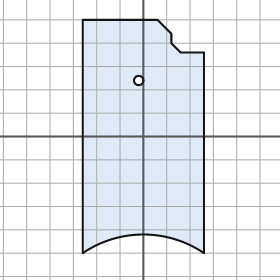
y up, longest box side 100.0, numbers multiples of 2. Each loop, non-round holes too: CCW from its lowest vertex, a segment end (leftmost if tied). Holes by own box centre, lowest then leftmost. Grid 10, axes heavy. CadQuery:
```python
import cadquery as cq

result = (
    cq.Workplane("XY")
    .moveTo(-26.0, -50.0)
    .threePointArc((0.0, -42.0), (26.0, -50.0))
    .lineTo(26.0, 36.0)
    .lineTo(16.0, 36.0)
    .lineTo(12.0, 40.0)
    .lineTo(12.0, 44.0)
    .lineTo(6.0, 50.0)
    .lineTo(-26.0, 50.0)
    .close()
    .moveTo(-2.0, 24.0)
    .circle(2.0)
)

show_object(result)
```